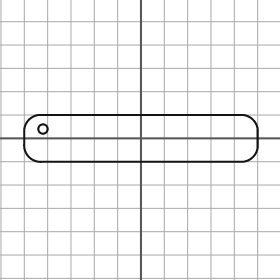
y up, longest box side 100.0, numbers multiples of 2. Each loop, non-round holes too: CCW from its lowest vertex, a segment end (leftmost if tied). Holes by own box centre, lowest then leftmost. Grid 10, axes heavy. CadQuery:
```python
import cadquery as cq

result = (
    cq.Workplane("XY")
    .moveTo(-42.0, -10.0)
    .lineTo(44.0, -10.0)
    .threePointArc((48.0, -8.0), (50.0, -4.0))
    .lineTo(50.0, 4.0)
    .threePointArc((48.0, 8.0), (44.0, 10.0))
    .lineTo(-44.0, 10.0)
    .threePointArc((-48.0, 8.0), (-50.0, 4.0))
    .lineTo(-50.0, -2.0)
    .threePointArc((-48.0, -8.0), (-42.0, -10.0))
    .close()
    .moveTo(-42.0, 4.0)
    .circle(2.0)
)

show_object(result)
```